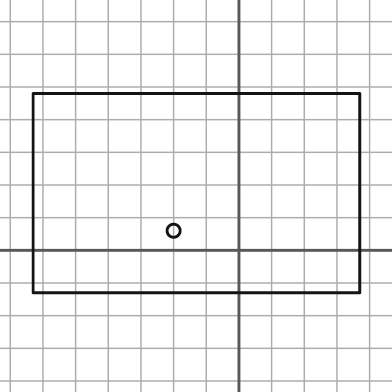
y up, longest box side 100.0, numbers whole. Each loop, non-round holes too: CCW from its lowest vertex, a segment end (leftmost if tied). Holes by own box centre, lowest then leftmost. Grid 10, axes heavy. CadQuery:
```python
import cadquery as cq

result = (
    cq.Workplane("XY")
    .moveTo(-63.0, -13.0)
    .lineTo(37.0, -13.0)
    .lineTo(37.0, 48.0)
    .lineTo(-63.0, 48.0)
    .close()
    .moveTo(-20.0, 6.0)
    .circle(2.0)
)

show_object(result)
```